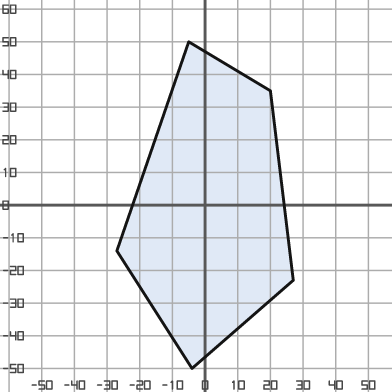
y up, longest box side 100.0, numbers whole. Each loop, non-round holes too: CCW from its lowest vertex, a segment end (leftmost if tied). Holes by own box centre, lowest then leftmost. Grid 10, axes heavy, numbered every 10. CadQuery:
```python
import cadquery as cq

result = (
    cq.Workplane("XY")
    .moveTo(-4.0, -50.0)
    .lineTo(27.0, -23.0)
    .lineTo(20.0, 35.0)
    .lineTo(-5.0, 50.0)
    .lineTo(-27.0, -14.0)
    .close()
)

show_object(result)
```